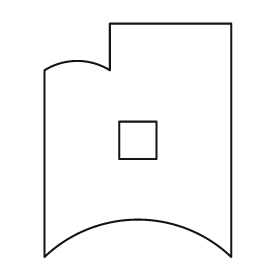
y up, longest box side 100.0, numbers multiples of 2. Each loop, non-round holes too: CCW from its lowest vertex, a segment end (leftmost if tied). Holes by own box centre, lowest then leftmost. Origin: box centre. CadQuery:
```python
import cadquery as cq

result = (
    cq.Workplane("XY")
    .moveTo(-40.0, -50.0)
    .threePointArc((0.0, -34.0), (40.0, -50.0))
    .lineTo(40.0, 50.0)
    .lineTo(-12.0, 50.0)
    .lineTo(-12.0, 30.0)
    .threePointArc((-26.0, 34.0), (-40.0, 30.0))
    .close()
    .moveTo(-8.0, -8.0)
    .lineTo(8.0, -8.0)
    .lineTo(8.0, 8.0)
    .lineTo(-8.0, 8.0)
    .close()
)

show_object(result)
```